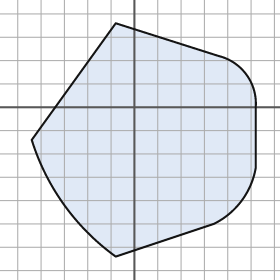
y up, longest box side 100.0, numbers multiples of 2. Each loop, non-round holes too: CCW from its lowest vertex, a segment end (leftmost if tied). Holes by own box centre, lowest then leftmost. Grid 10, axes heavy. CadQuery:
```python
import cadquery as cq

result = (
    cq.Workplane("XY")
    .moveTo(-8.0, -64.0)
    .lineTo(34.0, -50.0)
    .threePointArc((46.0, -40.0), (52.0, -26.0))
    .lineTo(52.0, 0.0)
    .threePointArc((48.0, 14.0), (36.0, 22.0))
    .lineTo(-8.0, 36.0)
    .lineTo(-44.0, -14.0)
    .threePointArc((-30.0, -42.0), (-8.0, -64.0))
    .close()
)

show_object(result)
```